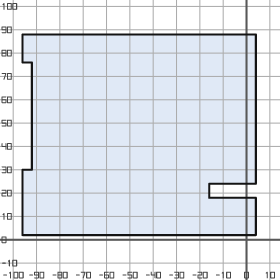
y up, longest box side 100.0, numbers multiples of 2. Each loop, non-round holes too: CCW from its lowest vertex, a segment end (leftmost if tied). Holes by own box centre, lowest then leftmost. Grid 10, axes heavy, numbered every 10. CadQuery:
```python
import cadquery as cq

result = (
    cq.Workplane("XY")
    .moveTo(-96.0, 2.0)
    .lineTo(4.0, 2.0)
    .lineTo(4.0, 18.0)
    .lineTo(-16.0, 18.0)
    .lineTo(-16.0, 24.0)
    .lineTo(4.0, 24.0)
    .lineTo(4.0, 88.0)
    .lineTo(-96.0, 88.0)
    .lineTo(-96.0, 76.0)
    .lineTo(-92.0, 76.0)
    .lineTo(-92.0, 30.0)
    .lineTo(-96.0, 30.0)
    .close()
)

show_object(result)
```